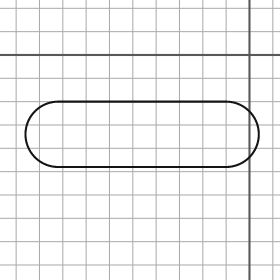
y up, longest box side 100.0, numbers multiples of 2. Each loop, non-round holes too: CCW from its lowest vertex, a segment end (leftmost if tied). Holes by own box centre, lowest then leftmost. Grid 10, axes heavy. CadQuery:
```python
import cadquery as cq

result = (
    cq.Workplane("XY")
    .moveTo(-82.0, -48.0)
    .lineTo(-10.0, -48.0)
    .threePointArc((4.0, -34.0), (-10.0, -20.0))
    .lineTo(-82.0, -20.0)
    .threePointArc((-96.0, -34.0), (-82.0, -48.0))
    .close()
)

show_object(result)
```